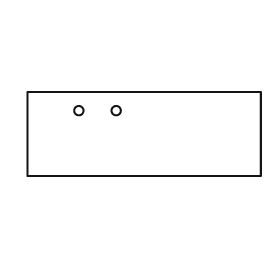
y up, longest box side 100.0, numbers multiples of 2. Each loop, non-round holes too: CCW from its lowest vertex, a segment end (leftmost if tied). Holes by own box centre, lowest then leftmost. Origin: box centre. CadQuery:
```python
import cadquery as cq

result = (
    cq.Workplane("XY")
    .moveTo(-50.0, -18.0)
    .lineTo(50.0, -18.0)
    .lineTo(50.0, 18.0)
    .lineTo(-50.0, 18.0)
    .close()
    .moveTo(-28.0, 10.0)
    .circle(2.0)
    .moveTo(-12.0, 10.0)
    .circle(2.0)
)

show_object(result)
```